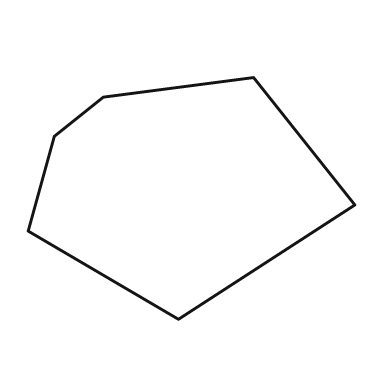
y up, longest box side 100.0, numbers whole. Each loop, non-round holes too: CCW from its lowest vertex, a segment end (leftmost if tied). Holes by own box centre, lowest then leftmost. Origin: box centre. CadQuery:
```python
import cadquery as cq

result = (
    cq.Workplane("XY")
    .moveTo(-4.0, -37.0)
    .lineTo(50.0, -2.0)
    .lineTo(19.0, 37.0)
    .lineTo(-27.0, 31.0)
    .lineTo(-42.0, 19.0)
    .lineTo(-50.0, -10.0)
    .close()
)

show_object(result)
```